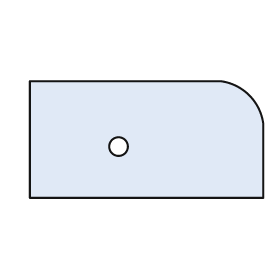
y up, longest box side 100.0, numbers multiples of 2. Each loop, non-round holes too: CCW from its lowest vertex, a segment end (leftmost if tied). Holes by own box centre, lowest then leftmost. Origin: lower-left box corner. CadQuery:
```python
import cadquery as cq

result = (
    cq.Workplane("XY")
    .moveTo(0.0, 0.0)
    .lineTo(100.0, 0.0)
    .lineTo(100.0, 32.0)
    .threePointArc((94.0, 44.0), (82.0, 50.0))
    .lineTo(0.0, 50.0)
    .close()
    .moveTo(38.0, 22.0)
    .circle(4.0)
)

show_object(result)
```